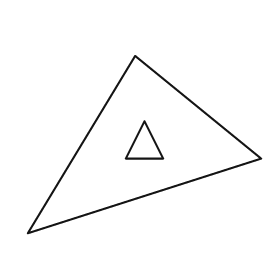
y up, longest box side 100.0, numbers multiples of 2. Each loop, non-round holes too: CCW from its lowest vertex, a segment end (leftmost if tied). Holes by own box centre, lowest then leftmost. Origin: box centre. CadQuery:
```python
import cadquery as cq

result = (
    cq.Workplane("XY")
    .moveTo(-50.0, -38.0)
    .lineTo(50.0, -6.0)
    .lineTo(-4.0, 38.0)
    .close()
    .moveTo(-8.0, -6.0)
    .lineTo(8.0, -6.0)
    .lineTo(0.0, 10.0)
    .close()
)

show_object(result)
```